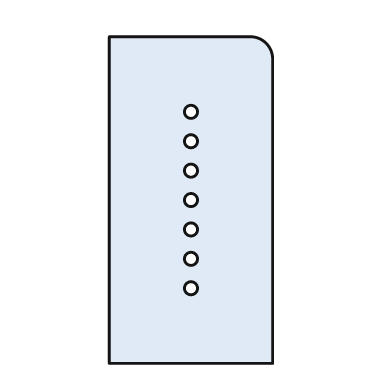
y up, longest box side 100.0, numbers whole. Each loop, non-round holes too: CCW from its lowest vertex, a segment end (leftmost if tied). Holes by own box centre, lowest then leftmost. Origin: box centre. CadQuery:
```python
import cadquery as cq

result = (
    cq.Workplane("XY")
    .moveTo(-25.0, -50.0)
    .lineTo(25.0, -50.0)
    .lineTo(25.0, 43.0)
    .threePointArc((23.0, 48.0), (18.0, 50.0))
    .lineTo(-25.0, 50.0)
    .close()
    .moveTo(0.0, -27.0)
    .circle(2.0)
    .moveTo(0.0, -18.0)
    .circle(2.0)
    .moveTo(0.0, -9.0)
    .circle(2.0)
    .moveTo(0.0, 0.0)
    .circle(2.0)
    .moveTo(0.0, 9.0)
    .circle(2.0)
    .moveTo(0.0, 18.0)
    .circle(2.0)
    .moveTo(0.0, 27.0)
    .circle(2.0)
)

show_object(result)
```